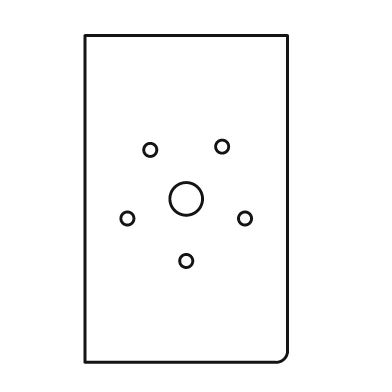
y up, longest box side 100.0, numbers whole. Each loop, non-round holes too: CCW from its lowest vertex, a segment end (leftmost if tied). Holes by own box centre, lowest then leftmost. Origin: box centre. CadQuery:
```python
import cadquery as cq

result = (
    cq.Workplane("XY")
    .moveTo(-31.0, -50.0)
    .lineTo(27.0, -50.0)
    .threePointArc((30.0, -49.0), (31.0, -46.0))
    .lineTo(31.0, 50.0)
    .lineTo(-31.0, 50.0)
    .close()
    .moveTo(0.0, -19.0)
    .circle(2.0)
    .moveTo(-18.0, -6.0)
    .circle(2.0)
    .moveTo(18.0, -6.0)
    .circle(2.0)
    .moveTo(0.0, 0.0)
    .circle(5.0)
    .moveTo(-11.0, 15.0)
    .circle(2.0)
    .moveTo(11.0, 16.0)
    .circle(2.0)
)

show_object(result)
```